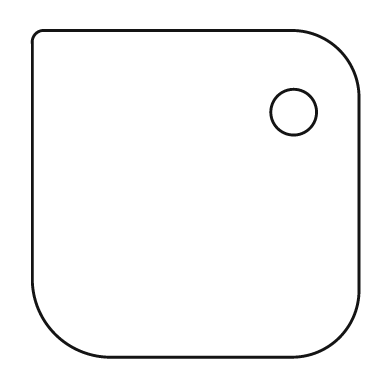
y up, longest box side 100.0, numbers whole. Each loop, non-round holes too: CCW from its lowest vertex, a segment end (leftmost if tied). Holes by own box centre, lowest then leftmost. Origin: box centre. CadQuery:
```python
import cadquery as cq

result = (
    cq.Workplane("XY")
    .moveTo(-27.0, -50.0)
    .lineTo(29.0, -50.0)
    .threePointArc((44.0, -44.0), (50.0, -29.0))
    .lineTo(50.0, 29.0)
    .threePointArc((44.0, 44.0), (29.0, 50.0))
    .lineTo(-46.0, 50.0)
    .threePointArc((-49.0, 49.0), (-50.0, 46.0))
    .lineTo(-50.0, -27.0)
    .threePointArc((-43.0, -43.0), (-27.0, -50.0))
    .close()
    .moveTo(30.0, 25.0)
    .circle(7.0)
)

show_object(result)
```